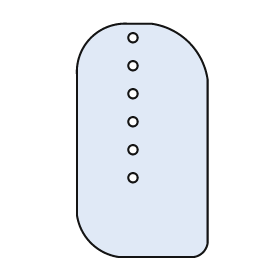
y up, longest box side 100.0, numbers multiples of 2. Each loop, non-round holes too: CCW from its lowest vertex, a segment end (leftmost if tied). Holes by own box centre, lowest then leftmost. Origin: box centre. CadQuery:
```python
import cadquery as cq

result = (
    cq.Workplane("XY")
    .moveTo(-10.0, -50.0)
    .lineTo(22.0, -50.0)
    .threePointArc((26.0, -48.0), (28.0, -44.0))
    .lineTo(28.0, 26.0)
    .threePointArc((20.0, 42.0), (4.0, 50.0))
    .lineTo(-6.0, 50.0)
    .threePointArc((-22.0, 44.0), (-28.0, 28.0))
    .lineTo(-28.0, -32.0)
    .threePointArc((-22.0, -44.0), (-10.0, -50.0))
    .close()
    .moveTo(-4.0, -16.0)
    .circle(2.0)
    .moveTo(-4.0, -4.0)
    .circle(2.0)
    .moveTo(-4.0, 8.0)
    .circle(2.0)
    .moveTo(-4.0, 20.0)
    .circle(2.0)
    .moveTo(-4.0, 32.0)
    .circle(2.0)
    .moveTo(-4.0, 44.0)
    .circle(2.0)
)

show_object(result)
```